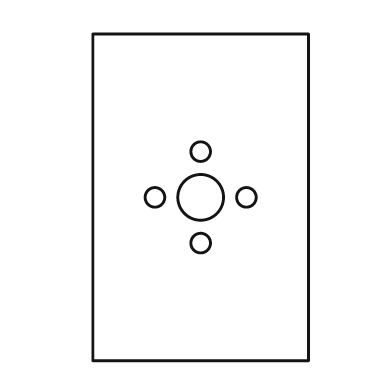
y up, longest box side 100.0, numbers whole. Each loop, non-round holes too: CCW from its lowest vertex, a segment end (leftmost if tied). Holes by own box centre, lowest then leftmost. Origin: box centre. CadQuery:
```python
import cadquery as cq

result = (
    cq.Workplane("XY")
    .moveTo(-33.0, -50.0)
    .lineTo(33.0, -50.0)
    .lineTo(33.0, 50.0)
    .lineTo(-33.0, 50.0)
    .close()
    .moveTo(0.0, -14.0)
    .circle(3.0)
    .moveTo(-14.0, 0.0)
    .circle(3.0)
    .moveTo(0.0, 0.0)
    .circle(7.0)
    .moveTo(14.0, 0.0)
    .circle(3.0)
    .moveTo(0.0, 14.0)
    .circle(3.0)
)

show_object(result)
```